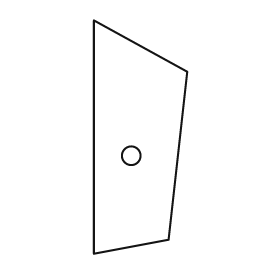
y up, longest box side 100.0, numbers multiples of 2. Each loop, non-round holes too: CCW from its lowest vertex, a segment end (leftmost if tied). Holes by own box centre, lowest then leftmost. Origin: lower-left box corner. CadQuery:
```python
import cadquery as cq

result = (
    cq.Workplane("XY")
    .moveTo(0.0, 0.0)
    .lineTo(32.0, 6.0)
    .lineTo(40.0, 78.0)
    .lineTo(0.0, 100.0)
    .close()
    .moveTo(16.0, 42.0)
    .circle(4.0)
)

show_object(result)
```